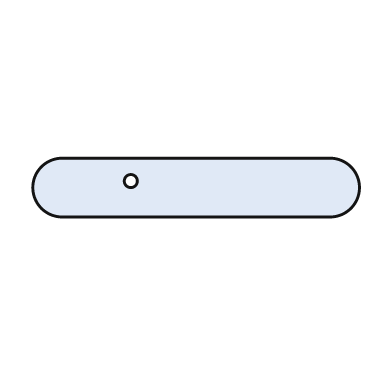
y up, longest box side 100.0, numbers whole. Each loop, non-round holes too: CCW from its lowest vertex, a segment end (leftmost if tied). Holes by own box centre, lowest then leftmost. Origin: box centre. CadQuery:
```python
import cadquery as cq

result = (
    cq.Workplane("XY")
    .moveTo(-41.0, -9.0)
    .lineTo(41.0, -9.0)
    .threePointArc((50.0, 0.0), (41.0, 9.0))
    .lineTo(-41.0, 9.0)
    .threePointArc((-50.0, 0.0), (-41.0, -9.0))
    .close()
    .moveTo(-20.0, 2.0)
    .circle(2.0)
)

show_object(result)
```